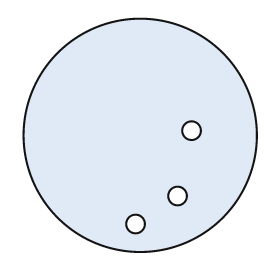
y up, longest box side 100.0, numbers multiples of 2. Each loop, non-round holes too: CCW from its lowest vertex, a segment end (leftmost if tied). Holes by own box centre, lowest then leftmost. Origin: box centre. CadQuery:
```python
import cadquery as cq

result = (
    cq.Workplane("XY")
    .moveTo(0.0, 0.0)
    .circle(50.0)
    .moveTo(-2.0, -38.0)
    .circle(4.0)
    .moveTo(16.0, -26.0)
    .circle(4.0)
    .moveTo(22.0, 2.0)
    .circle(4.0)
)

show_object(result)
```